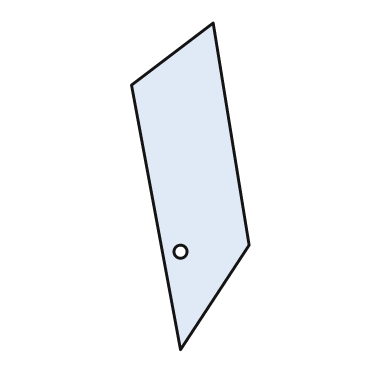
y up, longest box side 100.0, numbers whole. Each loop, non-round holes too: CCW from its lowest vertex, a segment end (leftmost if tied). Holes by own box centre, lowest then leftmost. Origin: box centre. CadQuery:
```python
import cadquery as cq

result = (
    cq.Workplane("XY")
    .moveTo(-3.0, -50.0)
    .lineTo(18.0, -18.0)
    .lineTo(7.0, 50.0)
    .lineTo(-18.0, 31.0)
    .close()
    .moveTo(-3.0, -20.0)
    .circle(2.0)
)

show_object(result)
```